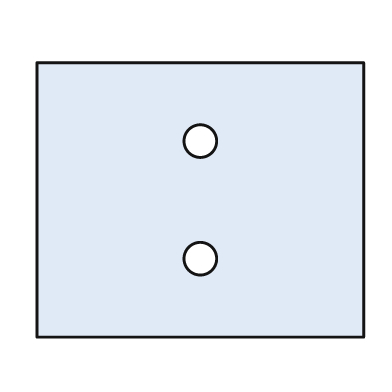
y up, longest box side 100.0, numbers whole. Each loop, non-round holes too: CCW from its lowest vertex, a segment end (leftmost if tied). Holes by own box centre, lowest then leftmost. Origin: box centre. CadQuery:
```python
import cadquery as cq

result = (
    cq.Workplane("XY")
    .moveTo(-50.0, -42.0)
    .lineTo(50.0, -42.0)
    .lineTo(50.0, 42.0)
    .lineTo(-50.0, 42.0)
    .close()
    .moveTo(0.0, -18.0)
    .circle(5.0)
    .moveTo(0.0, 18.0)
    .circle(5.0)
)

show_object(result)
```